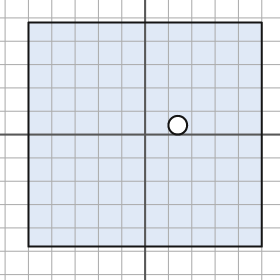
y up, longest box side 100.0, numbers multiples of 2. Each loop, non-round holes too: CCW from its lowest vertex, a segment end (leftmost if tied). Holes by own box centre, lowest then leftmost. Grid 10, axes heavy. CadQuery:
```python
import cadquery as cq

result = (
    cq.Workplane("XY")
    .moveTo(-50.0, -48.0)
    .lineTo(50.0, -48.0)
    .lineTo(50.0, 48.0)
    .lineTo(-50.0, 48.0)
    .close()
    .moveTo(14.0, 4.0)
    .circle(4.0)
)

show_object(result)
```